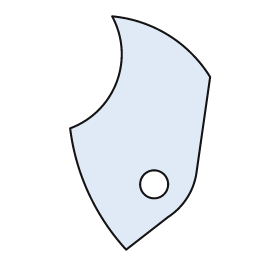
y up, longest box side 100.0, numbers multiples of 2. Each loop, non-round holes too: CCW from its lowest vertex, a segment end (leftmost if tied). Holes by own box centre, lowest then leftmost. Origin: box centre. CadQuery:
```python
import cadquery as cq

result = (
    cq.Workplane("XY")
    .moveTo(-6.0, -50.0)
    .lineTo(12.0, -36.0)
    .threePointArc((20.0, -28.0), (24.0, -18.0))
    .lineTo(30.0, 24.0)
    .threePointArc((12.0, 42.0), (-12.0, 50.0))
    .threePointArc((-10.0, 22.0), (-30.0, 2.0))
    .threePointArc((-22.0, -26.0), (-6.0, -50.0))
    .close()
    .moveTo(6.0, -22.0)
    .circle(6.0)
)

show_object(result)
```